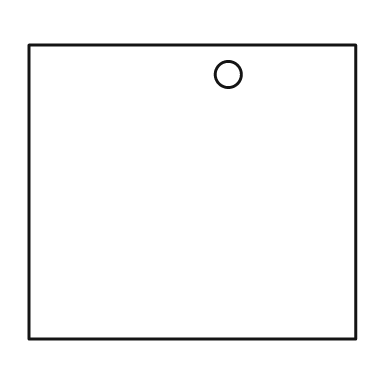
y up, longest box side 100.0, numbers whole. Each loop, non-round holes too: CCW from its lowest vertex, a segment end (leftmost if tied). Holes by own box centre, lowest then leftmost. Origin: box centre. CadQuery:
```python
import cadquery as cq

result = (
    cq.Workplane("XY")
    .moveTo(-50.0, -45.0)
    .lineTo(50.0, -45.0)
    .lineTo(50.0, 45.0)
    .lineTo(-50.0, 45.0)
    .close()
    .moveTo(11.0, 36.0)
    .circle(4.0)
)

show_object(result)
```